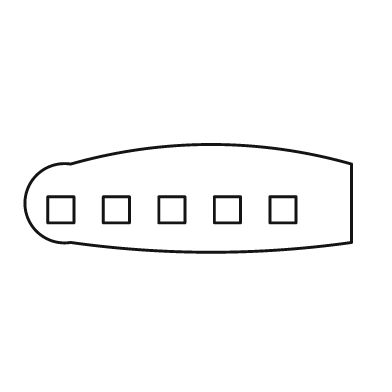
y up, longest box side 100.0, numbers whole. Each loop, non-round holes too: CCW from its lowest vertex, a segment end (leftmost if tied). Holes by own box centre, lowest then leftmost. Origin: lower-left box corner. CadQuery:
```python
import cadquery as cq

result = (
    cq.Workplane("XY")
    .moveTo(14.0, 3.0)
    .threePointArc((57.0, 0.0), (100.0, 3.0))
    .lineTo(100.0, 27.0)
    .threePointArc((57.0, 33.0), (14.0, 27.0))
    .threePointArc((0.0, 15.0), (14.0, 3.0))
    .close()
    .moveTo(7.0, 9.0)
    .lineTo(15.0, 9.0)
    .lineTo(15.0, 17.0)
    .lineTo(7.0, 17.0)
    .close()
    .moveTo(24.0, 9.0)
    .lineTo(32.0, 9.0)
    .lineTo(32.0, 17.0)
    .lineTo(24.0, 17.0)
    .close()
    .moveTo(41.0, 9.0)
    .lineTo(49.0, 9.0)
    .lineTo(49.0, 17.0)
    .lineTo(41.0, 17.0)
    .close()
    .moveTo(58.0, 9.0)
    .lineTo(66.0, 9.0)
    .lineTo(66.0, 17.0)
    .lineTo(58.0, 17.0)
    .close()
    .moveTo(75.0, 9.0)
    .lineTo(83.0, 9.0)
    .lineTo(83.0, 17.0)
    .lineTo(75.0, 17.0)
    .close()
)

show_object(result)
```